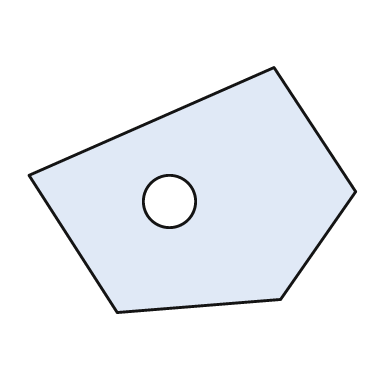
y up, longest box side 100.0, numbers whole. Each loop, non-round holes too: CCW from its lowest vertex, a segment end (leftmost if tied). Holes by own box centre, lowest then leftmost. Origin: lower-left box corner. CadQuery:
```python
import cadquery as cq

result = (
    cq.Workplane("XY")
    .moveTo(27.0, 0.0)
    .lineTo(77.0, 4.0)
    .lineTo(100.0, 37.0)
    .lineTo(75.0, 75.0)
    .lineTo(0.0, 42.0)
    .close()
    .moveTo(43.0, 34.0)
    .circle(8.0)
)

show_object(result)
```